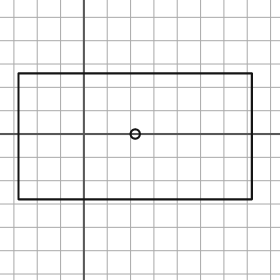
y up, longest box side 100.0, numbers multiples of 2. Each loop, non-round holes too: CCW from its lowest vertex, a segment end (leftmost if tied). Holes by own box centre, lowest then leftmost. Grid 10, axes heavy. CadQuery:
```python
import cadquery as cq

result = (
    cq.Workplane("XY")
    .moveTo(-28.0, -28.0)
    .lineTo(72.0, -28.0)
    .lineTo(72.0, 26.0)
    .lineTo(-28.0, 26.0)
    .close()
    .moveTo(22.0, 0.0)
    .circle(2.0)
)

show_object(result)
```